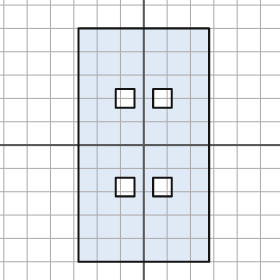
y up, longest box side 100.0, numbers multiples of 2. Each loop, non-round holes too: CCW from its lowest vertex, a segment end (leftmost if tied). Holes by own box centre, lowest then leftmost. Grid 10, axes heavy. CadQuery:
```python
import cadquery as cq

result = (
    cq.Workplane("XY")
    .moveTo(-28.0, -50.0)
    .lineTo(28.0, -50.0)
    .lineTo(28.0, 50.0)
    .lineTo(-28.0, 50.0)
    .close()
    .moveTo(-12.0, -22.0)
    .lineTo(-4.0, -22.0)
    .lineTo(-4.0, -14.0)
    .lineTo(-12.0, -14.0)
    .close()
    .moveTo(4.0, -22.0)
    .lineTo(12.0, -22.0)
    .lineTo(12.0, -14.0)
    .lineTo(4.0, -14.0)
    .close()
    .moveTo(-12.0, 16.0)
    .lineTo(-4.0, 16.0)
    .lineTo(-4.0, 24.0)
    .lineTo(-12.0, 24.0)
    .close()
    .moveTo(4.0, 16.0)
    .lineTo(12.0, 16.0)
    .lineTo(12.0, 24.0)
    .lineTo(4.0, 24.0)
    .close()
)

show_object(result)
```